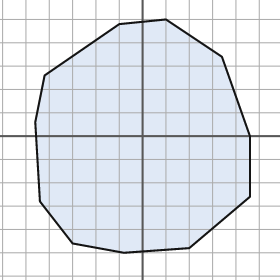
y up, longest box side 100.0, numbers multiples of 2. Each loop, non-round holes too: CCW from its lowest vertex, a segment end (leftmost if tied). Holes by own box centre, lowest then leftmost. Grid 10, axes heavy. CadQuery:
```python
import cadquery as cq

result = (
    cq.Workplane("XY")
    .moveTo(-8.0, -50.0)
    .lineTo(20.0, -48.0)
    .lineTo(46.0, -26.0)
    .lineTo(46.0, 0.0)
    .lineTo(34.0, 34.0)
    .lineTo(10.0, 50.0)
    .lineTo(-10.0, 48.0)
    .lineTo(-42.0, 26.0)
    .lineTo(-46.0, 6.0)
    .lineTo(-44.0, -28.0)
    .lineTo(-30.0, -46.0)
    .close()
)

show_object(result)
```